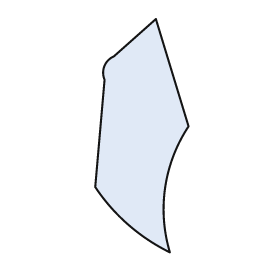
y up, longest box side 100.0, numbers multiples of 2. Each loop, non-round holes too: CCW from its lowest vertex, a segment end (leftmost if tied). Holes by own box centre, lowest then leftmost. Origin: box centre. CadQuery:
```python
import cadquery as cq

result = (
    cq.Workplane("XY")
    .moveTo(12.0, -50.0)
    .threePointArc((10.0, -22.0), (20.0, 4.0))
    .lineTo(6.0, 50.0)
    .lineTo(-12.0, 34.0)
    .threePointArc((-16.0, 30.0), (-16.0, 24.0))
    .lineTo(-20.0, -22.0)
    .threePointArc((-6.0, -38.0), (12.0, -50.0))
    .close()
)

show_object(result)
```